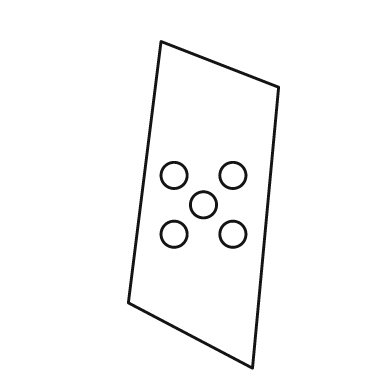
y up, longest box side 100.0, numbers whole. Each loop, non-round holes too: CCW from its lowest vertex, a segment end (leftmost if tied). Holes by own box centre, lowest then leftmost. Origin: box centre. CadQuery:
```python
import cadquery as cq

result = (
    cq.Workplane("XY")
    .moveTo(15.0, -50.0)
    .lineTo(23.0, 36.0)
    .lineTo(-13.0, 50.0)
    .lineTo(-23.0, -30.0)
    .close()
    .moveTo(-9.0, -9.0)
    .circle(4.0)
    .moveTo(9.0, -9.0)
    .circle(4.0)
    .moveTo(0.0, 0.0)
    .circle(4.0)
    .moveTo(-9.0, 9.0)
    .circle(4.0)
    .moveTo(9.0, 9.0)
    .circle(4.0)
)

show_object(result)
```